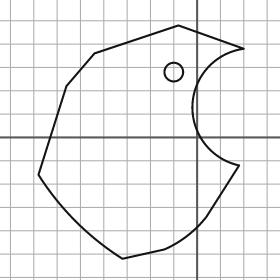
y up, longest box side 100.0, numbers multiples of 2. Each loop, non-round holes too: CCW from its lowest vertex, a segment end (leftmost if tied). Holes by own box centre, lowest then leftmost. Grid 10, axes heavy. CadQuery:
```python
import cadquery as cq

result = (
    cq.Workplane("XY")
    .moveTo(-32.0, -52.0)
    .lineTo(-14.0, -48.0)
    .threePointArc((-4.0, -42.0), (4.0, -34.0))
    .lineTo(18.0, -12.0)
    .threePointArc((-2.0, 14.0), (20.0, 38.0))
    .lineTo(-8.0, 48.0)
    .lineTo(-44.0, 36.0)
    .lineTo(-56.0, 22.0)
    .lineTo(-68.0, -16.0)
    .threePointArc((-52.0, -36.0), (-32.0, -52.0))
    .close()
    .moveTo(-10.0, 28.0)
    .circle(4.0)
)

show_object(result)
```